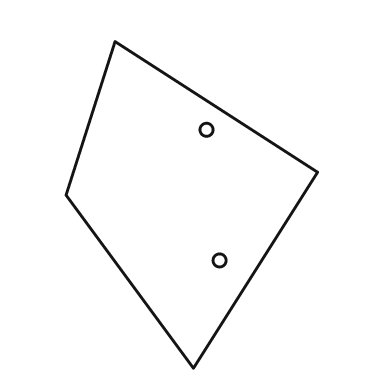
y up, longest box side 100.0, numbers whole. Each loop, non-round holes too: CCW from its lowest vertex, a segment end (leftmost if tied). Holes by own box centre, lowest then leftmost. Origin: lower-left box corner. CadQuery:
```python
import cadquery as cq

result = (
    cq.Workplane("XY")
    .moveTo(39.0, 0.0)
    .lineTo(77.0, 60.0)
    .lineTo(15.0, 100.0)
    .lineTo(0.0, 53.0)
    .close()
    .moveTo(47.0, 33.0)
    .circle(2.0)
    .moveTo(43.0, 73.0)
    .circle(2.0)
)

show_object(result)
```